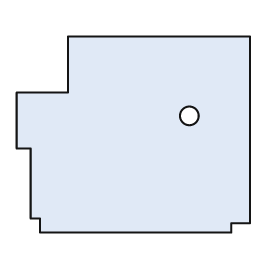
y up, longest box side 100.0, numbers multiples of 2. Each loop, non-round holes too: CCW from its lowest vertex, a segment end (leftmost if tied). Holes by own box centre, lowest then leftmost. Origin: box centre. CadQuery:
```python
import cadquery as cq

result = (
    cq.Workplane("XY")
    .moveTo(-40.0, -42.0)
    .lineTo(42.0, -42.0)
    .lineTo(42.0, -38.0)
    .lineTo(50.0, -38.0)
    .lineTo(50.0, 42.0)
    .lineTo(-28.0, 42.0)
    .lineTo(-28.0, 18.0)
    .lineTo(-50.0, 18.0)
    .lineTo(-50.0, -6.0)
    .lineTo(-44.0, -6.0)
    .lineTo(-44.0, -36.0)
    .lineTo(-40.0, -36.0)
    .close()
    .moveTo(24.0, 8.0)
    .circle(4.0)
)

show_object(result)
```